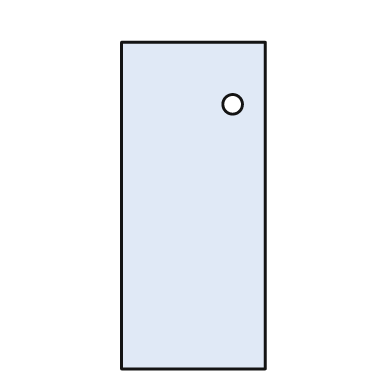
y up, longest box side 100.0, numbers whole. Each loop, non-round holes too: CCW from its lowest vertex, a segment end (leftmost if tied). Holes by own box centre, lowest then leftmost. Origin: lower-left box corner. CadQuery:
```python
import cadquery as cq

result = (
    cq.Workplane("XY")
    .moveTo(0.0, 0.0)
    .lineTo(44.0, 0.0)
    .lineTo(44.0, 100.0)
    .lineTo(0.0, 100.0)
    .close()
    .moveTo(34.0, 81.0)
    .circle(3.0)
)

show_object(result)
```